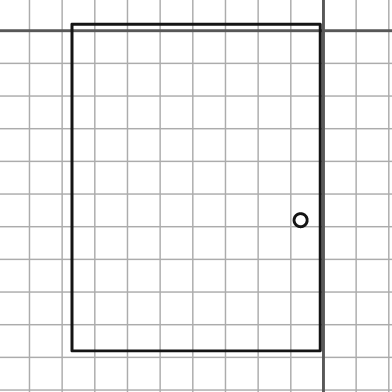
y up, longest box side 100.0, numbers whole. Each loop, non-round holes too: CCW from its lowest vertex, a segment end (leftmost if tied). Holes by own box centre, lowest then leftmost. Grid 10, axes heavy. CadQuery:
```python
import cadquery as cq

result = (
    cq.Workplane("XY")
    .moveTo(-77.0, -98.0)
    .lineTo(-1.0, -98.0)
    .lineTo(-1.0, 2.0)
    .lineTo(-77.0, 2.0)
    .close()
    .moveTo(-7.0, -58.0)
    .circle(2.0)
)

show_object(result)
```